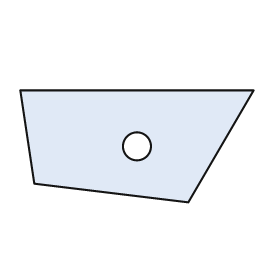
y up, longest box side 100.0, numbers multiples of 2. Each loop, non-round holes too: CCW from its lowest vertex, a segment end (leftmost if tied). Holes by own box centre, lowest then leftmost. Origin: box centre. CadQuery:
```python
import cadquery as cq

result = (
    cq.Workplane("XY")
    .moveTo(22.0, -24.0)
    .lineTo(50.0, 24.0)
    .lineTo(-50.0, 24.0)
    .lineTo(-44.0, -16.0)
    .close()
    .moveTo(0.0, 0.0)
    .circle(6.0)
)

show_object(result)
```